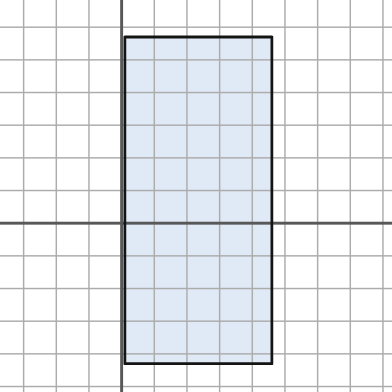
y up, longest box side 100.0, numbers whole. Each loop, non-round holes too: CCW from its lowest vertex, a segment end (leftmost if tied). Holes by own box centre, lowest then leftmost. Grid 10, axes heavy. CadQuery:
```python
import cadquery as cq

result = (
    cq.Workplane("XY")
    .moveTo(1.0, -43.0)
    .lineTo(46.0, -43.0)
    .lineTo(46.0, 57.0)
    .lineTo(1.0, 57.0)
    .close()
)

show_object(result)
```